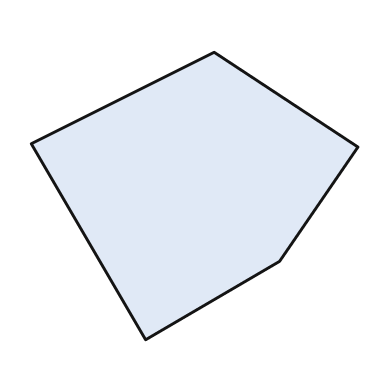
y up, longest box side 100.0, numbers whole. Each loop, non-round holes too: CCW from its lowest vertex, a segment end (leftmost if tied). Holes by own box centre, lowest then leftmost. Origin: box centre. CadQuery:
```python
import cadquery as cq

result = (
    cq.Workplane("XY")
    .moveTo(-15.0, -44.0)
    .lineTo(26.0, -20.0)
    .lineTo(50.0, 15.0)
    .lineTo(6.0, 44.0)
    .lineTo(-50.0, 16.0)
    .close()
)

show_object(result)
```